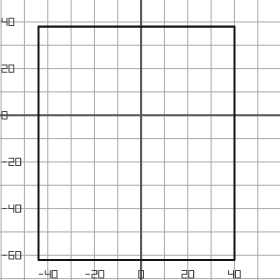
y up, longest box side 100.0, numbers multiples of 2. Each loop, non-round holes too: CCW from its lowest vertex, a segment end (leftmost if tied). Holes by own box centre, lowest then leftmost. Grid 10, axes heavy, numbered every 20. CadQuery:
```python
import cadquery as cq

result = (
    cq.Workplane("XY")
    .moveTo(-44.0, -62.0)
    .lineTo(40.0, -62.0)
    .lineTo(40.0, 38.0)
    .lineTo(-44.0, 38.0)
    .close()
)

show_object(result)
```